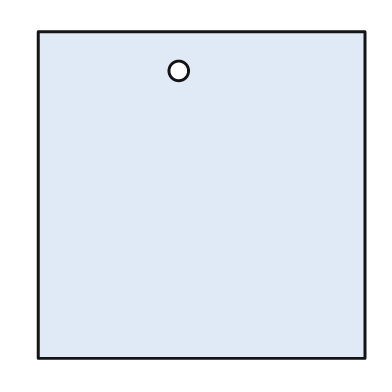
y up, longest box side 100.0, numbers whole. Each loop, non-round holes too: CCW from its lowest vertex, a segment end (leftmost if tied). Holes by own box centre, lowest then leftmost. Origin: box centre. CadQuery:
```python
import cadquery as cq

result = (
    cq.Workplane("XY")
    .moveTo(-50.0, -50.0)
    .lineTo(50.0, -50.0)
    .lineTo(50.0, 50.0)
    .lineTo(-50.0, 50.0)
    .close()
    .moveTo(-7.0, 38.0)
    .circle(3.0)
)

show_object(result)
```